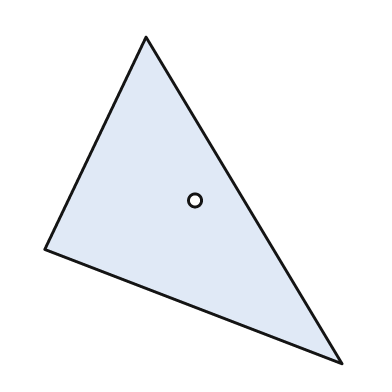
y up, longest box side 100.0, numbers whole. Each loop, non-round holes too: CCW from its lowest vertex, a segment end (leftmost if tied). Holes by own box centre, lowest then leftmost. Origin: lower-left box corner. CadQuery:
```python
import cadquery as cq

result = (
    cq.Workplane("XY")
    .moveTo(91.0, 0.0)
    .lineTo(31.0, 100.0)
    .lineTo(0.0, 35.0)
    .close()
    .moveTo(46.0, 50.0)
    .circle(2.0)
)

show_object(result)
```